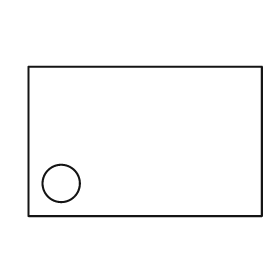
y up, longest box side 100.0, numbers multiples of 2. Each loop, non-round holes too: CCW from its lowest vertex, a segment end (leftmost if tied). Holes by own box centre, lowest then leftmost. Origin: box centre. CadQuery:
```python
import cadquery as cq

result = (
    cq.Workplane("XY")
    .moveTo(-50.0, -32.0)
    .lineTo(50.0, -32.0)
    .lineTo(50.0, 32.0)
    .lineTo(-50.0, 32.0)
    .close()
    .moveTo(-36.0, -18.0)
    .circle(8.0)
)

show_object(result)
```